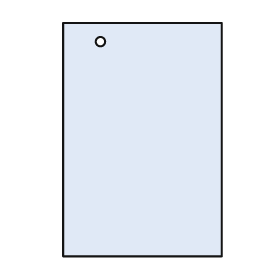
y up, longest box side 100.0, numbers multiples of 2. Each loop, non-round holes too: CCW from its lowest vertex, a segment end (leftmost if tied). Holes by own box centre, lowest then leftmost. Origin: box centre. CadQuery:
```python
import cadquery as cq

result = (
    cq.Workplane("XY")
    .moveTo(-34.0, -50.0)
    .lineTo(34.0, -50.0)
    .lineTo(34.0, 50.0)
    .lineTo(-34.0, 50.0)
    .close()
    .moveTo(-18.0, 42.0)
    .circle(2.0)
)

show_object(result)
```